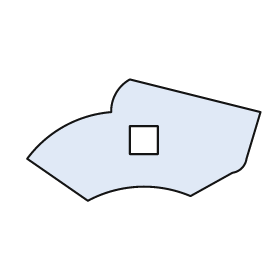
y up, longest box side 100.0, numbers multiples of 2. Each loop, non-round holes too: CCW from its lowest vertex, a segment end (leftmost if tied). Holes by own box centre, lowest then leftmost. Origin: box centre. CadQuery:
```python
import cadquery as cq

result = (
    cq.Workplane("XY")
    .moveTo(-24.0, -26.0)
    .threePointArc((-2.0, -20.0), (20.0, -24.0))
    .lineTo(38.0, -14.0)
    .threePointArc((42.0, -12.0), (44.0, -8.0))
    .lineTo(50.0, 12.0)
    .lineTo(-6.0, 26.0)
    .threePointArc((-12.0, 20.0), (-14.0, 12.0))
    .threePointArc((-34.0, 6.0), (-50.0, -8.0))
    .close()
    .moveTo(-6.0, -6.0)
    .lineTo(6.0, -6.0)
    .lineTo(6.0, 6.0)
    .lineTo(-6.0, 6.0)
    .close()
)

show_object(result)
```